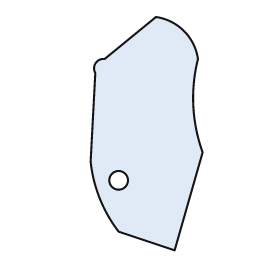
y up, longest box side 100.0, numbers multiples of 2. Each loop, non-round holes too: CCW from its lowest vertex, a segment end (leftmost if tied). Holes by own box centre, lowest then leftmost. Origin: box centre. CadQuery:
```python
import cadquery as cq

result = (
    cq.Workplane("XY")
    .moveTo(12.0, -50.0)
    .lineTo(24.0, -8.0)
    .threePointArc((20.0, 12.0), (22.0, 32.0))
    .threePointArc((16.0, 44.0), (4.0, 50.0))
    .lineTo(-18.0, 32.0)
    .threePointArc((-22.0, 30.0), (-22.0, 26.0))
    .lineTo(-24.0, -12.0)
    .threePointArc((-20.0, -28.0), (-12.0, -42.0))
    .close()
    .moveTo(-12.0, -20.0)
    .circle(4.0)
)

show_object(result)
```